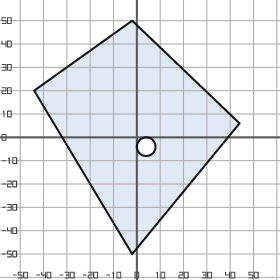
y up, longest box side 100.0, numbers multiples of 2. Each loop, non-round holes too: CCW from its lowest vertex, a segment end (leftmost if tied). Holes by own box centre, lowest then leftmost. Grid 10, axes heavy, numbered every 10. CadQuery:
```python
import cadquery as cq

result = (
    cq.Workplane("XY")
    .moveTo(-2.0, -50.0)
    .lineTo(44.0, 6.0)
    .lineTo(-2.0, 50.0)
    .lineTo(-44.0, 20.0)
    .close()
    .moveTo(4.0, -4.0)
    .circle(4.0)
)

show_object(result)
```